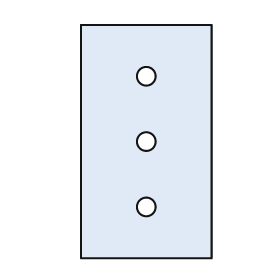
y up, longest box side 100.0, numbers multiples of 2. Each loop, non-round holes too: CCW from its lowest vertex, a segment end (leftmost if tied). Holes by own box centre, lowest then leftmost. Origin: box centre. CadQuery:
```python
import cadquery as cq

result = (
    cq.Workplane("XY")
    .moveTo(-28.0, -50.0)
    .lineTo(28.0, -50.0)
    .lineTo(28.0, 50.0)
    .lineTo(-28.0, 50.0)
    .close()
    .moveTo(0.0, -28.0)
    .circle(4.0)
    .moveTo(0.0, 0.0)
    .circle(4.0)
    .moveTo(0.0, 28.0)
    .circle(4.0)
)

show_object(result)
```